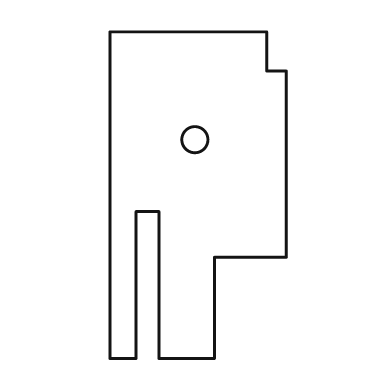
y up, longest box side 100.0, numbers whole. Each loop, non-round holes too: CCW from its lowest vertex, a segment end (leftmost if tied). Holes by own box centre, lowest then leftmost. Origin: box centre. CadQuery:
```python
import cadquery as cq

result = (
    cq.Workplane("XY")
    .moveTo(-27.0, -50.0)
    .lineTo(-19.0, -50.0)
    .lineTo(-19.0, -5.0)
    .lineTo(-12.0, -5.0)
    .lineTo(-12.0, -50.0)
    .lineTo(5.0, -50.0)
    .lineTo(5.0, -19.0)
    .lineTo(27.0, -19.0)
    .lineTo(27.0, 38.0)
    .lineTo(21.0, 38.0)
    .lineTo(21.0, 50.0)
    .lineTo(-27.0, 50.0)
    .close()
    .moveTo(-1.0, 17.0)
    .circle(4.0)
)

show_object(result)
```